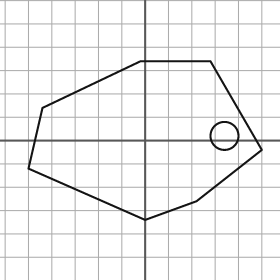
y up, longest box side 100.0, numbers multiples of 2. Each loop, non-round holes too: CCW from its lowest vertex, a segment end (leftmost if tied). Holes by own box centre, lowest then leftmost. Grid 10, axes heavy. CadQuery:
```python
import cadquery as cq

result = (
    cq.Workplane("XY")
    .moveTo(0.0, -34.0)
    .lineTo(22.0, -26.0)
    .lineTo(50.0, -4.0)
    .lineTo(28.0, 34.0)
    .lineTo(-2.0, 34.0)
    .lineTo(-44.0, 14.0)
    .lineTo(-50.0, -12.0)
    .close()
    .moveTo(34.0, 2.0)
    .circle(6.0)
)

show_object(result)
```